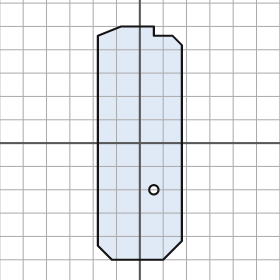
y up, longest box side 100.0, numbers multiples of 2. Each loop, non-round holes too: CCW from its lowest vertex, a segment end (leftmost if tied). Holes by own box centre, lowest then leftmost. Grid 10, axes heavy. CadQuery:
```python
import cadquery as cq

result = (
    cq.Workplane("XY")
    .moveTo(-12.0, -50.0)
    .lineTo(10.0, -50.0)
    .lineTo(18.0, -42.0)
    .lineTo(18.0, 42.0)
    .lineTo(14.0, 46.0)
    .lineTo(6.0, 46.0)
    .lineTo(6.0, 50.0)
    .lineTo(-8.0, 50.0)
    .lineTo(-18.0, 46.0)
    .lineTo(-18.0, -44.0)
    .close()
    .moveTo(6.0, -20.0)
    .circle(2.0)
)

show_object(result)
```